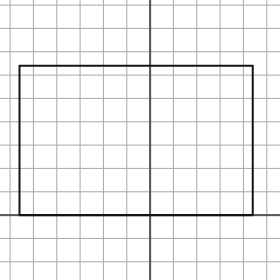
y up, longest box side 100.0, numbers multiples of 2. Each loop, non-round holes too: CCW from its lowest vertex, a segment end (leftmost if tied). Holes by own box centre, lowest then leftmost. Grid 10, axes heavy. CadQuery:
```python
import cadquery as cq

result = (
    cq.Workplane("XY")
    .moveTo(-56.0, 0.0)
    .lineTo(44.0, 0.0)
    .lineTo(44.0, 64.0)
    .lineTo(-56.0, 64.0)
    .close()
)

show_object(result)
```